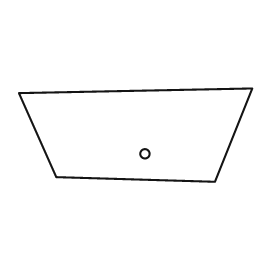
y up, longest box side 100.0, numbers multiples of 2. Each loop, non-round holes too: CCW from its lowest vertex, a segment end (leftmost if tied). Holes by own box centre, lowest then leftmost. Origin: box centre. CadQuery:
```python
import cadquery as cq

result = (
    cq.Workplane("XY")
    .moveTo(34.0, -20.0)
    .lineTo(50.0, 20.0)
    .lineTo(-50.0, 18.0)
    .lineTo(-34.0, -18.0)
    .close()
    .moveTo(4.0, -8.0)
    .circle(2.0)
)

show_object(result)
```